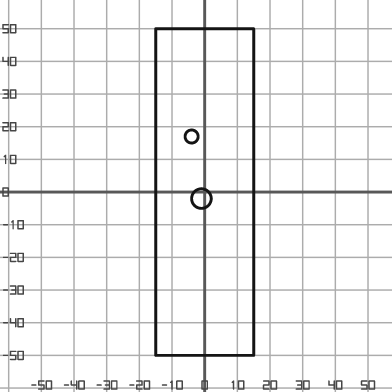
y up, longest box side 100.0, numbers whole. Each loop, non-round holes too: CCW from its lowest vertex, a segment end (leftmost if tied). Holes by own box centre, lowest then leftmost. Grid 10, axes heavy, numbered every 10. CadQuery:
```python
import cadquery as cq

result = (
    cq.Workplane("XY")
    .moveTo(-15.0, -50.0)
    .lineTo(15.0, -50.0)
    .lineTo(15.0, 50.0)
    .lineTo(-15.0, 50.0)
    .close()
    .moveTo(-1.0, -2.0)
    .circle(3.0)
    .moveTo(-4.0, 17.0)
    .circle(2.0)
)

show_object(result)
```